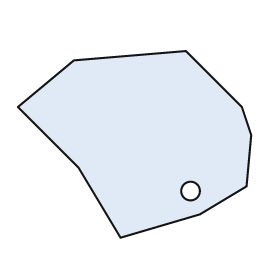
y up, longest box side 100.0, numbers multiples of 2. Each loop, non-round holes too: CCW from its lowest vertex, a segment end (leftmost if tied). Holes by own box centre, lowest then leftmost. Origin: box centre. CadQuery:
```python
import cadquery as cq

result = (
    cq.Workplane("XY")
    .moveTo(-6.0, -40.0)
    .lineTo(28.0, -30.0)
    .lineTo(48.0, -18.0)
    .lineTo(50.0, 4.0)
    .lineTo(46.0, 16.0)
    .lineTo(22.0, 40.0)
    .lineTo(-26.0, 36.0)
    .lineTo(-50.0, 16.0)
    .lineTo(-24.0, -10.0)
    .close()
    .moveTo(24.0, -20.0)
    .circle(4.0)
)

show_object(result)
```